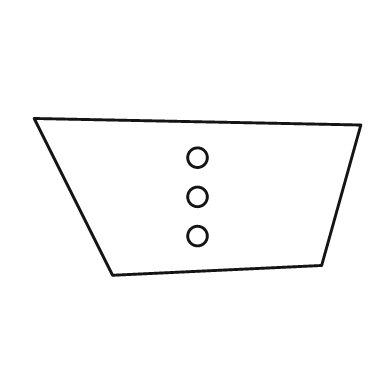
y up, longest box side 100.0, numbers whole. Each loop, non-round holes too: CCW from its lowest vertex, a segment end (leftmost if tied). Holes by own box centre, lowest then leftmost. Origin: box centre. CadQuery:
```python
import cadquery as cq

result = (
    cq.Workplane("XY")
    .moveTo(-26.0, -24.0)
    .lineTo(38.0, -21.0)
    .lineTo(50.0, 22.0)
    .lineTo(-50.0, 24.0)
    .close()
    .moveTo(0.0, -12.0)
    .circle(3.0)
    .moveTo(0.0, 0.0)
    .circle(3.0)
    .moveTo(0.0, 12.0)
    .circle(3.0)
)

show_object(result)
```